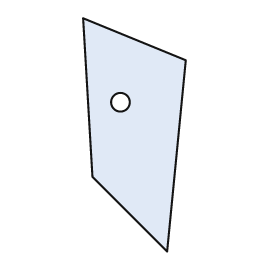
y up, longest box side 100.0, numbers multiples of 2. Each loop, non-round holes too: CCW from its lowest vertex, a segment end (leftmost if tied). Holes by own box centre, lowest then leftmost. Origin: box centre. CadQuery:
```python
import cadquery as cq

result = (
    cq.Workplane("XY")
    .moveTo(14.0, -50.0)
    .lineTo(22.0, 32.0)
    .lineTo(-22.0, 50.0)
    .lineTo(-18.0, -18.0)
    .close()
    .moveTo(-6.0, 14.0)
    .circle(4.0)
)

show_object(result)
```